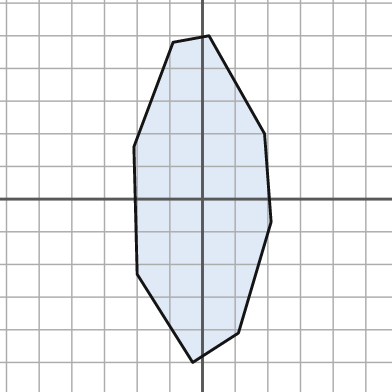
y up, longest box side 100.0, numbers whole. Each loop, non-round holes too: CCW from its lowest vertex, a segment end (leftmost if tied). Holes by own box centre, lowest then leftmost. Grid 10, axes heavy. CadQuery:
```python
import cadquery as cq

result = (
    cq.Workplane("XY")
    .moveTo(-3.0, -50.0)
    .lineTo(11.0, -41.0)
    .lineTo(21.0, -7.0)
    .lineTo(19.0, 20.0)
    .lineTo(2.0, 50.0)
    .lineTo(-9.0, 48.0)
    .lineTo(-21.0, 16.0)
    .lineTo(-20.0, -23.0)
    .close()
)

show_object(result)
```